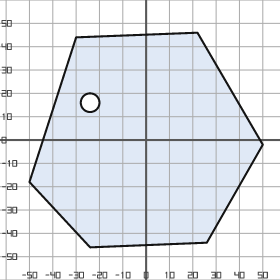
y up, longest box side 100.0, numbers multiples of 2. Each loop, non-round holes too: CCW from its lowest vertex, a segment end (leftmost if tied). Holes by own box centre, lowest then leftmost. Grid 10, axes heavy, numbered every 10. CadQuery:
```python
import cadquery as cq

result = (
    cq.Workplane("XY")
    .moveTo(-24.0, -46.0)
    .lineTo(26.0, -44.0)
    .lineTo(50.0, -2.0)
    .lineTo(22.0, 46.0)
    .lineTo(-30.0, 44.0)
    .lineTo(-50.0, -18.0)
    .close()
    .moveTo(-24.0, 16.0)
    .circle(4.0)
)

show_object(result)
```